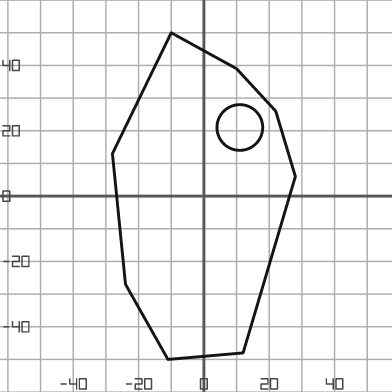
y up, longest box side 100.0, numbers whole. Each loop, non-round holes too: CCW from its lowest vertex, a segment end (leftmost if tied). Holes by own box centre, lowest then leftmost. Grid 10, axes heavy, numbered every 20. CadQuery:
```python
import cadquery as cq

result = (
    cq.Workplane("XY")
    .moveTo(-11.0, -50.0)
    .lineTo(12.0, -48.0)
    .lineTo(28.0, 6.0)
    .lineTo(22.0, 26.0)
    .lineTo(10.0, 39.0)
    .lineTo(-10.0, 50.0)
    .lineTo(-28.0, 13.0)
    .lineTo(-24.0, -27.0)
    .close()
    .moveTo(11.0, 21.0)
    .circle(7.0)
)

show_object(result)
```